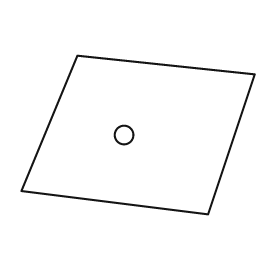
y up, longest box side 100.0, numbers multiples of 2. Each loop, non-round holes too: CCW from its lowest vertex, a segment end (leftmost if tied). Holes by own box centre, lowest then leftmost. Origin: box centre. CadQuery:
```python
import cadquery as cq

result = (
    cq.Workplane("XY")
    .moveTo(30.0, -34.0)
    .lineTo(50.0, 26.0)
    .lineTo(-26.0, 34.0)
    .lineTo(-50.0, -24.0)
    .close()
    .moveTo(-6.0, 0.0)
    .circle(4.0)
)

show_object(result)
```